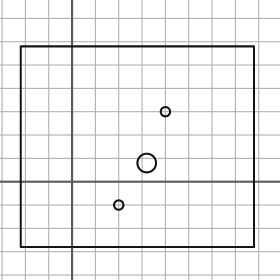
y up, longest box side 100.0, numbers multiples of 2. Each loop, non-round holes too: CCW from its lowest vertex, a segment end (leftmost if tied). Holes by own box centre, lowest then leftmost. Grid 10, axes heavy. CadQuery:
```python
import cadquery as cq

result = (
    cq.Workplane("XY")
    .moveTo(-22.0, -28.0)
    .lineTo(78.0, -28.0)
    .lineTo(78.0, 58.0)
    .lineTo(-22.0, 58.0)
    .close()
    .moveTo(20.0, -10.0)
    .circle(2.0)
    .moveTo(32.0, 8.0)
    .circle(4.0)
    .moveTo(40.0, 30.0)
    .circle(2.0)
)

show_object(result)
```